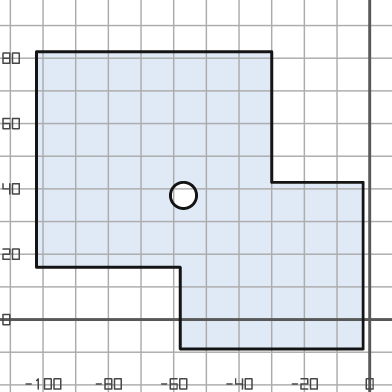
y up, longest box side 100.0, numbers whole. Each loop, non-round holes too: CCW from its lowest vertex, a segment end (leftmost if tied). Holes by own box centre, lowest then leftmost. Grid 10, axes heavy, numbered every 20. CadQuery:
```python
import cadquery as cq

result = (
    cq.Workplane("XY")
    .moveTo(-58.0, -9.0)
    .lineTo(-2.0, -9.0)
    .lineTo(-2.0, 42.0)
    .lineTo(-30.0, 42.0)
    .lineTo(-30.0, 82.0)
    .lineTo(-102.0, 82.0)
    .lineTo(-102.0, 16.0)
    .lineTo(-58.0, 16.0)
    .close()
    .moveTo(-57.0, 38.0)
    .circle(4.0)
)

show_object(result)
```